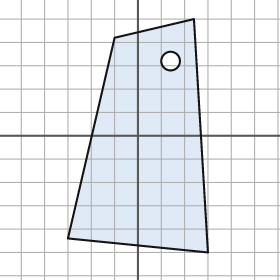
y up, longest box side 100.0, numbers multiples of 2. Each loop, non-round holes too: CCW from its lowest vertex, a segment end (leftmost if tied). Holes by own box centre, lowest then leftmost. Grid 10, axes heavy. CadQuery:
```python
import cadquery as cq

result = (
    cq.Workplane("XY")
    .moveTo(30.0, -50.0)
    .lineTo(24.0, 50.0)
    .lineTo(-10.0, 42.0)
    .lineTo(-30.0, -44.0)
    .close()
    .moveTo(14.0, 32.0)
    .circle(4.0)
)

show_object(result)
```